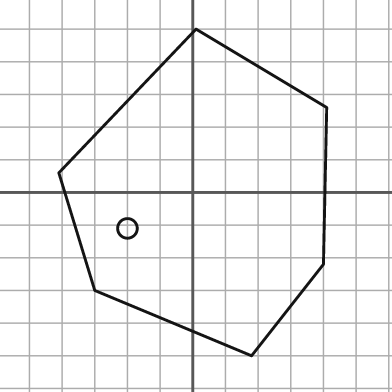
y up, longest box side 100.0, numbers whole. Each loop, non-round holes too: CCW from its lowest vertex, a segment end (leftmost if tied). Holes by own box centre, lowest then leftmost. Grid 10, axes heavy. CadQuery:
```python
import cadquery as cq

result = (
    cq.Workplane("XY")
    .moveTo(18.0, -50.0)
    .lineTo(40.0, -22.0)
    .lineTo(41.0, 26.0)
    .lineTo(1.0, 50.0)
    .lineTo(-41.0, 6.0)
    .lineTo(-30.0, -30.0)
    .close()
    .moveTo(-20.0, -11.0)
    .circle(3.0)
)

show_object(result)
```